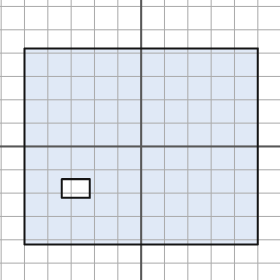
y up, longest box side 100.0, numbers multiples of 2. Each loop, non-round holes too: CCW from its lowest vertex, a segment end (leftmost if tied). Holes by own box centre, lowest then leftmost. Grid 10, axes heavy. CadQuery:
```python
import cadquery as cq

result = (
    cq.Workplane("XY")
    .moveTo(-50.0, -42.0)
    .lineTo(50.0, -42.0)
    .lineTo(50.0, 42.0)
    .lineTo(-50.0, 42.0)
    .close()
    .moveTo(-34.0, -22.0)
    .lineTo(-22.0, -22.0)
    .lineTo(-22.0, -14.0)
    .lineTo(-34.0, -14.0)
    .close()
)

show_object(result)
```